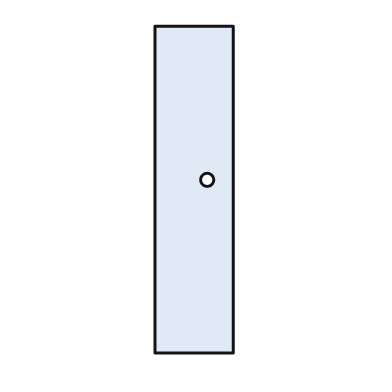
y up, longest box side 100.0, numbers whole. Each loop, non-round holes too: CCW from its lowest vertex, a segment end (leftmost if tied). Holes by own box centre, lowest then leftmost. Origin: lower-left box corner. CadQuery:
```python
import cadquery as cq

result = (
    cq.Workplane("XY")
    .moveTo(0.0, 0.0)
    .lineTo(24.0, 0.0)
    .lineTo(24.0, 100.0)
    .lineTo(0.0, 100.0)
    .close()
    .moveTo(16.0, 53.0)
    .circle(2.0)
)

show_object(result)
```